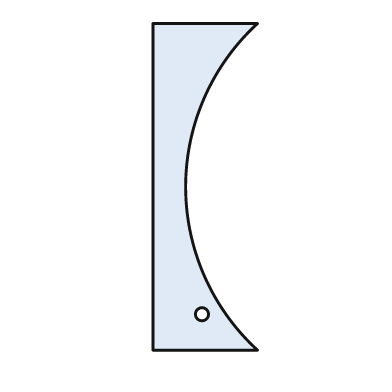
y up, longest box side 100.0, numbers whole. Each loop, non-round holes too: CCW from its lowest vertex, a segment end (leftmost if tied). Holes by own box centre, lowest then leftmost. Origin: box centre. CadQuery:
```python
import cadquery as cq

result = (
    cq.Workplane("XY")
    .moveTo(-16.0, -50.0)
    .lineTo(16.0, -50.0)
    .threePointArc((-6.0, 0.0), (16.0, 50.0))
    .lineTo(-16.0, 50.0)
    .close()
    .moveTo(-1.0, -39.0)
    .circle(2.0)
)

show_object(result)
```